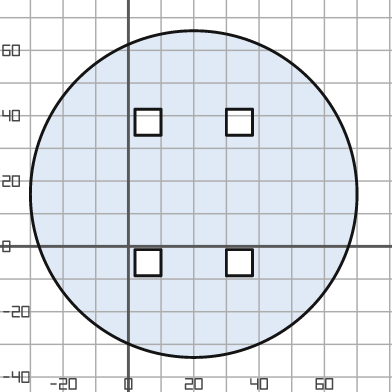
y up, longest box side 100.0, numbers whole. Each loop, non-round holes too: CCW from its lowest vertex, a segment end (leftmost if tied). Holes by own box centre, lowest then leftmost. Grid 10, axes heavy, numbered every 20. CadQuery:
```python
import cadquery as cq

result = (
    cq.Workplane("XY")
    .moveTo(20.0, 16.0)
    .circle(50.0)
    .moveTo(2.0, -9.0)
    .lineTo(10.0, -9.0)
    .lineTo(10.0, -1.0)
    .lineTo(2.0, -1.0)
    .close()
    .moveTo(30.0, -9.0)
    .lineTo(38.0, -9.0)
    .lineTo(38.0, -1.0)
    .lineTo(30.0, -1.0)
    .close()
    .moveTo(2.0, 34.0)
    .lineTo(10.0, 34.0)
    .lineTo(10.0, 42.0)
    .lineTo(2.0, 42.0)
    .close()
    .moveTo(30.0, 34.0)
    .lineTo(38.0, 34.0)
    .lineTo(38.0, 42.0)
    .lineTo(30.0, 42.0)
    .close()
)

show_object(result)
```